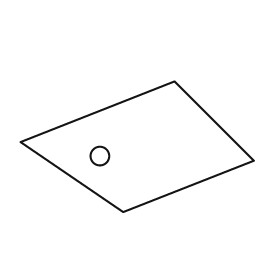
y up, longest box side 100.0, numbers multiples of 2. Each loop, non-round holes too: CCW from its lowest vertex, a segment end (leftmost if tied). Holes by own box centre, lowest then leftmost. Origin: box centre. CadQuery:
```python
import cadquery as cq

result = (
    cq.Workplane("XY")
    .moveTo(-6.0, -28.0)
    .lineTo(50.0, -6.0)
    .lineTo(16.0, 28.0)
    .lineTo(-50.0, 2.0)
    .close()
    .moveTo(-16.0, -4.0)
    .circle(4.0)
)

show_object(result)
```